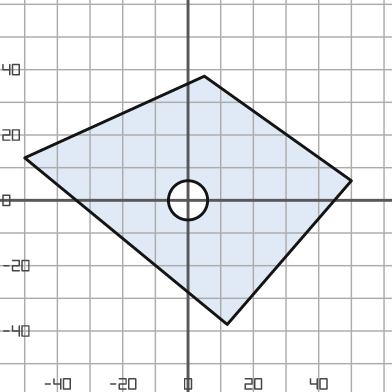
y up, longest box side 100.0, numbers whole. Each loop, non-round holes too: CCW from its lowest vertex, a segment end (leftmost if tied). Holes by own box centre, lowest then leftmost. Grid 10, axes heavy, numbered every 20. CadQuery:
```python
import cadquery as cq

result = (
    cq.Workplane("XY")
    .moveTo(12.0, -38.0)
    .lineTo(50.0, 6.0)
    .lineTo(5.0, 38.0)
    .lineTo(-50.0, 13.0)
    .close()
    .moveTo(0.0, 0.0)
    .circle(6.0)
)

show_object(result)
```